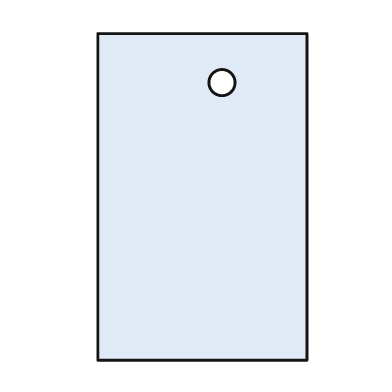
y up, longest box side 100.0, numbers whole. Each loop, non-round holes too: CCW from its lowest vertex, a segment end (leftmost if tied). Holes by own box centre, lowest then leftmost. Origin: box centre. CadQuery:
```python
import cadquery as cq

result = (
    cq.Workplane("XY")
    .moveTo(-32.0, -50.0)
    .lineTo(32.0, -50.0)
    .lineTo(32.0, 50.0)
    .lineTo(-32.0, 50.0)
    .close()
    .moveTo(6.0, 35.0)
    .circle(4.0)
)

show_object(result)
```